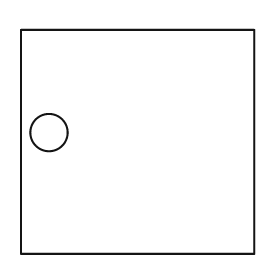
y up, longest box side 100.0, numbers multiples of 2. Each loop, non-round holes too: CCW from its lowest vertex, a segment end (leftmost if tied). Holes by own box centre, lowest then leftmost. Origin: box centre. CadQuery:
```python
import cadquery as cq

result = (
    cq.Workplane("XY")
    .moveTo(-50.0, -48.0)
    .lineTo(50.0, -48.0)
    .lineTo(50.0, 48.0)
    .lineTo(-50.0, 48.0)
    .close()
    .moveTo(-38.0, 4.0)
    .circle(8.0)
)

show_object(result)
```